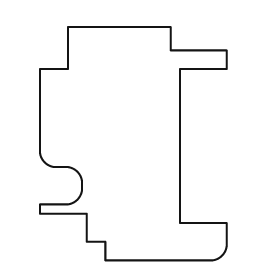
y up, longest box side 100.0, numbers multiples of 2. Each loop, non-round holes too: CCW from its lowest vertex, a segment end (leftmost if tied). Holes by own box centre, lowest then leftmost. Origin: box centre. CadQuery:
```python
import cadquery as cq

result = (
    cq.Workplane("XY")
    .moveTo(-12.0, -50.0)
    .lineTo(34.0, -50.0)
    .threePointArc((38.0, -48.0), (40.0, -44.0))
    .lineTo(40.0, -34.0)
    .lineTo(20.0, -34.0)
    .lineTo(20.0, 32.0)
    .lineTo(40.0, 32.0)
    .lineTo(40.0, 40.0)
    .lineTo(16.0, 40.0)
    .lineTo(16.0, 50.0)
    .lineTo(-28.0, 50.0)
    .lineTo(-28.0, 32.0)
    .lineTo(-40.0, 32.0)
    .lineTo(-40.0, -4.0)
    .threePointArc((-38.0, -8.0), (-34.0, -10.0))
    .lineTo(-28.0, -10.0)
    .threePointArc((-24.0, -12.0), (-22.0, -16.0))
    .lineTo(-22.0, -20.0)
    .threePointArc((-24.0, -24.0), (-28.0, -26.0))
    .lineTo(-40.0, -26.0)
    .lineTo(-40.0, -30.0)
    .lineTo(-20.0, -30.0)
    .lineTo(-20.0, -42.0)
    .lineTo(-12.0, -42.0)
    .close()
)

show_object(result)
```